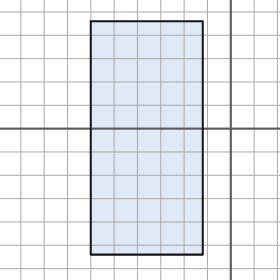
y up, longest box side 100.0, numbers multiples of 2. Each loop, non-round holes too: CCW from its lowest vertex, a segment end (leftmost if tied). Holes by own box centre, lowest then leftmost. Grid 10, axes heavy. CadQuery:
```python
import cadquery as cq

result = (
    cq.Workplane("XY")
    .moveTo(-60.0, -54.0)
    .lineTo(-12.0, -54.0)
    .lineTo(-12.0, 46.0)
    .lineTo(-60.0, 46.0)
    .close()
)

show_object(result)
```